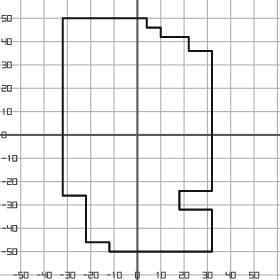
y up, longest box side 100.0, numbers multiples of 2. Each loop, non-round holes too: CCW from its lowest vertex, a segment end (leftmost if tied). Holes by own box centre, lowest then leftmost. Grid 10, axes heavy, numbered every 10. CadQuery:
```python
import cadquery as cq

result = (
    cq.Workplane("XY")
    .moveTo(-12.0, -50.0)
    .lineTo(32.0, -50.0)
    .lineTo(32.0, -32.0)
    .lineTo(18.0, -32.0)
    .lineTo(18.0, -24.0)
    .lineTo(32.0, -24.0)
    .lineTo(32.0, 36.0)
    .lineTo(22.0, 36.0)
    .lineTo(22.0, 42.0)
    .lineTo(10.0, 42.0)
    .lineTo(10.0, 46.0)
    .lineTo(4.0, 46.0)
    .lineTo(4.0, 50.0)
    .lineTo(-32.0, 50.0)
    .lineTo(-32.0, -26.0)
    .lineTo(-22.0, -26.0)
    .lineTo(-22.0, -46.0)
    .lineTo(-12.0, -46.0)
    .close()
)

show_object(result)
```